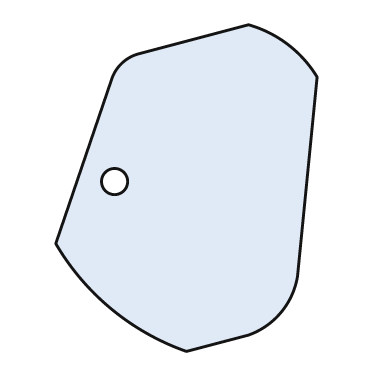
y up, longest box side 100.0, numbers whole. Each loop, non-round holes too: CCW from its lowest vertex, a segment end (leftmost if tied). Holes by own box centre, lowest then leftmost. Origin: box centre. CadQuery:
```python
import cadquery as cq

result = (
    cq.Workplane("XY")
    .moveTo(0.0, -50.0)
    .lineTo(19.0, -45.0)
    .threePointArc((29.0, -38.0), (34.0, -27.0))
    .lineTo(40.0, 34.0)
    .threePointArc((31.0, 44.0), (19.0, 50.0))
    .lineTo(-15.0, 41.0)
    .threePointArc((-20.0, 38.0), (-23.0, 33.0))
    .lineTo(-40.0, -17.0)
    .threePointArc((-23.0, -37.0), (0.0, -50.0))
    .close()
    .moveTo(-22.0, 2.0)
    .circle(4.0)
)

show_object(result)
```